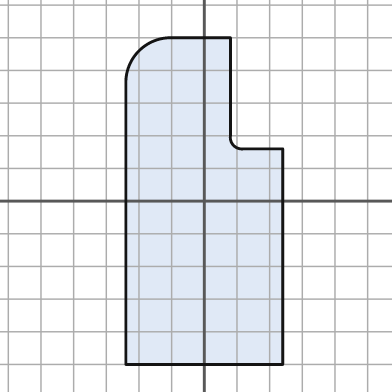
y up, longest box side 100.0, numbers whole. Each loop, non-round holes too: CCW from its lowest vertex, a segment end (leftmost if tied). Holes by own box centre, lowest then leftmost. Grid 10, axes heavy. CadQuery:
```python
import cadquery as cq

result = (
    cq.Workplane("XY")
    .moveTo(-24.0, -50.0)
    .lineTo(24.0, -50.0)
    .lineTo(24.0, 16.0)
    .lineTo(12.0, 16.0)
    .threePointArc((9.0, 17.0), (8.0, 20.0))
    .lineTo(8.0, 50.0)
    .lineTo(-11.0, 50.0)
    .threePointArc((-20.0, 46.0), (-24.0, 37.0))
    .close()
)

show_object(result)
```